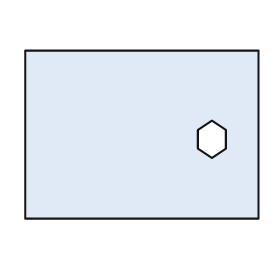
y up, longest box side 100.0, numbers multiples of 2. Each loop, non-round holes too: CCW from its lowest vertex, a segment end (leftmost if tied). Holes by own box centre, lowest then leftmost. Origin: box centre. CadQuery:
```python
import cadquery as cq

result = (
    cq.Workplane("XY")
    .moveTo(-50.0, -36.0)
    .lineTo(50.0, -36.0)
    .lineTo(50.0, 36.0)
    .lineTo(-50.0, 36.0)
    .close()
    .moveTo(30.0, -10.0)
    .lineTo(36.0, -6.0)
    .lineTo(36.0, 2.0)
    .lineTo(30.0, 6.0)
    .lineTo(24.0, 2.0)
    .lineTo(24.0, -6.0)
    .close()
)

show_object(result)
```